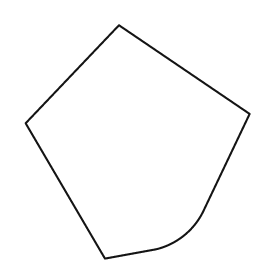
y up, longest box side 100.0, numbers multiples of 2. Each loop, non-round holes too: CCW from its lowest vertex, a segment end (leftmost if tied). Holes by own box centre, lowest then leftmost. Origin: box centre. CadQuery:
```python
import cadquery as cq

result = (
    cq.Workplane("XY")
    .moveTo(-14.0, -50.0)
    .lineTo(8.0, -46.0)
    .threePointArc((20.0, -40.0), (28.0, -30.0))
    .lineTo(48.0, 12.0)
    .lineTo(-8.0, 50.0)
    .lineTo(-48.0, 8.0)
    .close()
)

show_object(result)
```